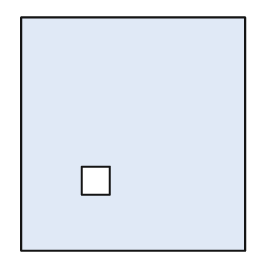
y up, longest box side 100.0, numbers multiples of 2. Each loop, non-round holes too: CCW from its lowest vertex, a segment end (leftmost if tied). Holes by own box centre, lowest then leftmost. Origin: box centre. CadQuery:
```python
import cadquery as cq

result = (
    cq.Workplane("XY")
    .moveTo(-48.0, -50.0)
    .lineTo(48.0, -50.0)
    .lineTo(48.0, 50.0)
    .lineTo(-48.0, 50.0)
    .close()
    .moveTo(-22.0, -26.0)
    .lineTo(-10.0, -26.0)
    .lineTo(-10.0, -14.0)
    .lineTo(-22.0, -14.0)
    .close()
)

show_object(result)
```